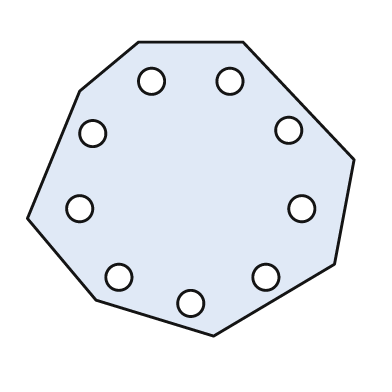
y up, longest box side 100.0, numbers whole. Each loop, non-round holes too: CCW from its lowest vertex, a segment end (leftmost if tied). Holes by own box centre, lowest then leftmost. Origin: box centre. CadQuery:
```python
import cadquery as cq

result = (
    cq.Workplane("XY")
    .moveTo(7.0, -45.0)
    .lineTo(44.0, -23.0)
    .lineTo(50.0, 9.0)
    .lineTo(16.0, 45.0)
    .lineTo(-16.0, 45.0)
    .lineTo(-34.0, 30.0)
    .lineTo(-50.0, -9.0)
    .lineTo(-29.0, -34.0)
    .close()
    .moveTo(0.0, -35.0)
    .circle(4.0)
    .moveTo(-22.0, -27.0)
    .circle(4.0)
    .moveTo(23.0, -27.0)
    .circle(4.0)
    .moveTo(-34.0, -6.0)
    .circle(4.0)
    .moveTo(34.0, -6.0)
    .circle(4.0)
    .moveTo(-30.0, 17.0)
    .circle(4.0)
    .moveTo(30.0, 18.0)
    .circle(4.0)
    .moveTo(-12.0, 33.0)
    .circle(4.0)
    .moveTo(12.0, 33.0)
    .circle(4.0)
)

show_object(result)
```